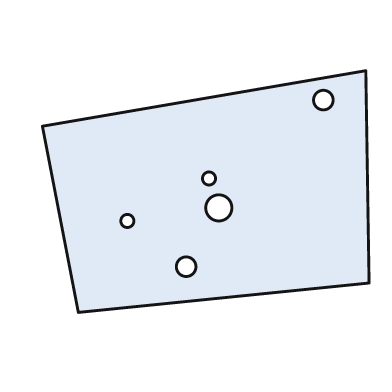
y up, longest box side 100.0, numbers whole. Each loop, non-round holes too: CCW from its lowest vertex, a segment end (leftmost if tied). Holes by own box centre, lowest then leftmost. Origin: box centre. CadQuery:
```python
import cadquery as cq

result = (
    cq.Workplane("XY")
    .moveTo(-39.0, -37.0)
    .lineTo(50.0, -28.0)
    .lineTo(49.0, 37.0)
    .lineTo(-50.0, 20.0)
    .close()
    .moveTo(-6.0, -23.0)
    .circle(3.0)
    .moveTo(-24.0, -9.0)
    .circle(2.0)
    .moveTo(4.0, -5.0)
    .circle(4.0)
    .moveTo(1.0, 4.0)
    .circle(2.0)
    .moveTo(36.0, 28.0)
    .circle(3.0)
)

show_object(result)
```